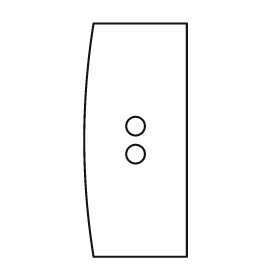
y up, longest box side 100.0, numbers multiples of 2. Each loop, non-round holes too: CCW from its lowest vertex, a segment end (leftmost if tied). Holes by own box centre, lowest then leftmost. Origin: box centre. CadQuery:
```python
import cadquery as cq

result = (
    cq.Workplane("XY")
    .moveTo(-18.0, -50.0)
    .lineTo(22.0, -50.0)
    .lineTo(22.0, 50.0)
    .lineTo(-18.0, 50.0)
    .threePointArc((-22.0, 0.0), (-18.0, -50.0))
    .close()
    .moveTo(0.0, -6.0)
    .circle(4.0)
    .moveTo(0.0, 6.0)
    .circle(4.0)
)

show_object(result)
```